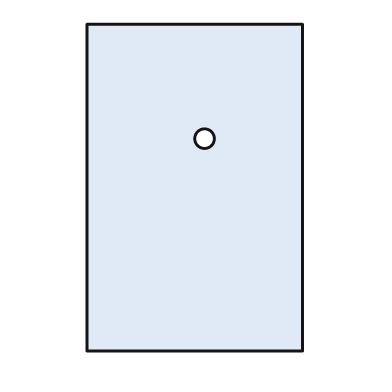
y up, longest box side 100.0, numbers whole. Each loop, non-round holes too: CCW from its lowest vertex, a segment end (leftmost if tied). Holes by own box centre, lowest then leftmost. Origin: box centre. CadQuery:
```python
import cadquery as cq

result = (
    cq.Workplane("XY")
    .moveTo(-33.0, -50.0)
    .lineTo(33.0, -50.0)
    .lineTo(33.0, 50.0)
    .lineTo(-33.0, 50.0)
    .close()
    .moveTo(3.0, 15.0)
    .circle(3.0)
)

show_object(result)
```